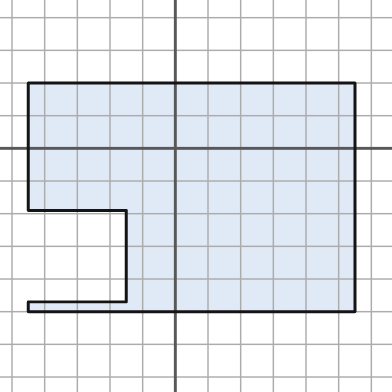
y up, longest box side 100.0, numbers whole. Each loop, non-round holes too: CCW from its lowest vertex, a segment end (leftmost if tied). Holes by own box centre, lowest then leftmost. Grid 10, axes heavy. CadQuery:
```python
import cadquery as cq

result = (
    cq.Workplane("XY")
    .moveTo(-45.0, -50.0)
    .lineTo(55.0, -50.0)
    .lineTo(55.0, 20.0)
    .lineTo(-45.0, 20.0)
    .lineTo(-45.0, -19.0)
    .lineTo(-15.0, -19.0)
    .lineTo(-15.0, -47.0)
    .lineTo(-45.0, -47.0)
    .close()
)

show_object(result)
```